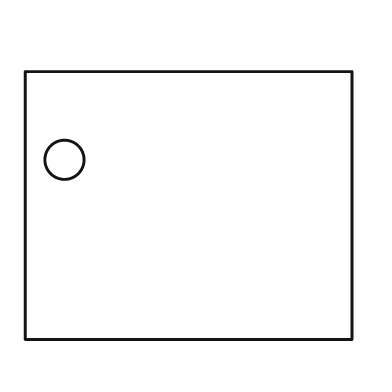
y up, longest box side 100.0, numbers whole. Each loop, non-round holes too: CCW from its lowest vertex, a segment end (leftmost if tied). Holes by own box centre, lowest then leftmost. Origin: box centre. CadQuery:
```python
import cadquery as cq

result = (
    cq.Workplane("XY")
    .moveTo(-50.0, -41.0)
    .lineTo(50.0, -41.0)
    .lineTo(50.0, 41.0)
    .lineTo(-50.0, 41.0)
    .close()
    .moveTo(-38.0, 14.0)
    .circle(6.0)
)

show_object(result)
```